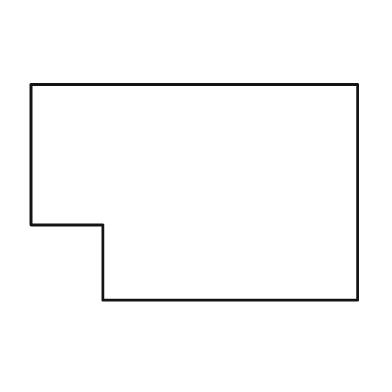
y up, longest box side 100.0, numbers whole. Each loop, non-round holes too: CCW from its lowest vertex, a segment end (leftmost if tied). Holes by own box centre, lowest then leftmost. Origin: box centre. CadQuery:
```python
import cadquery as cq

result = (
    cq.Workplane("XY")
    .moveTo(-28.0, -33.0)
    .lineTo(50.0, -33.0)
    .lineTo(50.0, 33.0)
    .lineTo(-50.0, 33.0)
    .lineTo(-50.0, -10.0)
    .lineTo(-28.0, -10.0)
    .close()
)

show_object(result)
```